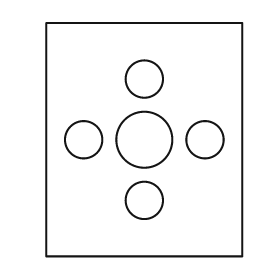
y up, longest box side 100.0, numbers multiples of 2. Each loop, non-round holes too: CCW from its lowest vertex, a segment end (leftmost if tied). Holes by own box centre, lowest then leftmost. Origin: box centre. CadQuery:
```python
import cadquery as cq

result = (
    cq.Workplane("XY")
    .moveTo(-42.0, -50.0)
    .lineTo(42.0, -50.0)
    .lineTo(42.0, 50.0)
    .lineTo(-42.0, 50.0)
    .close()
    .moveTo(0.0, -26.0)
    .circle(8.0)
    .moveTo(-26.0, 0.0)
    .circle(8.0)
    .moveTo(0.0, 0.0)
    .circle(12.0)
    .moveTo(26.0, 0.0)
    .circle(8.0)
    .moveTo(0.0, 26.0)
    .circle(8.0)
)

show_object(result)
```